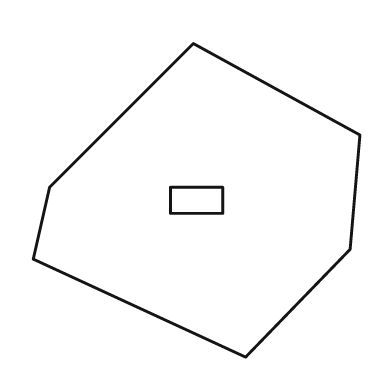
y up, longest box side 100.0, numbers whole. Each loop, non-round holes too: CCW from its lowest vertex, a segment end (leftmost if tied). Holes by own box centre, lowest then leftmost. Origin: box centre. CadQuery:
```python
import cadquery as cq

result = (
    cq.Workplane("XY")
    .moveTo(15.0, -48.0)
    .lineTo(47.0, -15.0)
    .lineTo(50.0, 20.0)
    .lineTo(-1.0, 48.0)
    .lineTo(-45.0, 4.0)
    .lineTo(-50.0, -18.0)
    .close()
    .moveTo(-8.0, -4.0)
    .lineTo(8.0, -4.0)
    .lineTo(8.0, 4.0)
    .lineTo(-8.0, 4.0)
    .close()
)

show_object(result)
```